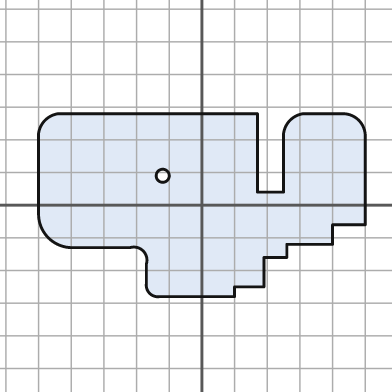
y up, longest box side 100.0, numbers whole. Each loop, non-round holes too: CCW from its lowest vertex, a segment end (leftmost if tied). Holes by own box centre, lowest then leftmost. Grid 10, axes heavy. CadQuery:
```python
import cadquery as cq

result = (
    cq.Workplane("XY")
    .moveTo(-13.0, -28.0)
    .lineTo(10.0, -28.0)
    .lineTo(10.0, -25.0)
    .lineTo(19.0, -25.0)
    .lineTo(19.0, -16.0)
    .lineTo(26.0, -16.0)
    .lineTo(26.0, -12.0)
    .lineTo(40.0, -12.0)
    .lineTo(40.0, -6.0)
    .lineTo(50.0, -6.0)
    .lineTo(50.0, 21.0)
    .threePointArc((48.0, 26.0), (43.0, 28.0))
    .lineTo(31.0, 28.0)
    .threePointArc((27.0, 26.0), (25.0, 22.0))
    .lineTo(25.0, 4.0)
    .lineTo(17.0, 4.0)
    .lineTo(17.0, 28.0)
    .lineTo(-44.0, 28.0)
    .threePointArc((-48.0, 26.0), (-50.0, 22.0))
    .lineTo(-50.0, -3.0)
    .threePointArc((-47.0, -10.0), (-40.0, -13.0))
    .lineTo(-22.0, -13.0)
    .threePointArc((-18.0, -14.0), (-17.0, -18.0))
    .lineTo(-17.0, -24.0)
    .threePointArc((-16.0, -27.0), (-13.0, -28.0))
    .close()
    .moveTo(-12.0, 9.0)
    .circle(2.0)
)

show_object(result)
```